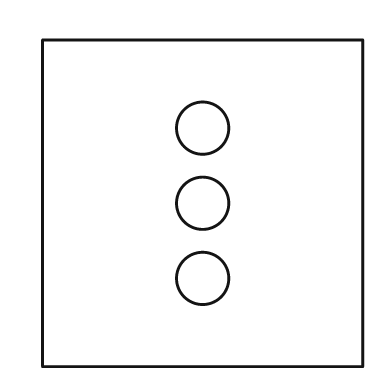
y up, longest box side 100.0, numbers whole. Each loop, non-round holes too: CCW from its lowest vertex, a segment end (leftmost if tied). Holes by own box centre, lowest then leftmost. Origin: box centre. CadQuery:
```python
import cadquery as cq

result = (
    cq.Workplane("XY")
    .moveTo(-49.0, -50.0)
    .lineTo(49.0, -50.0)
    .lineTo(49.0, 50.0)
    .lineTo(-49.0, 50.0)
    .close()
    .moveTo(0.0, -23.0)
    .circle(8.0)
    .moveTo(0.0, 0.0)
    .circle(8.0)
    .moveTo(0.0, 23.0)
    .circle(8.0)
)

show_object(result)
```